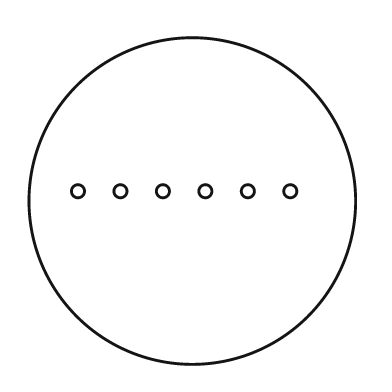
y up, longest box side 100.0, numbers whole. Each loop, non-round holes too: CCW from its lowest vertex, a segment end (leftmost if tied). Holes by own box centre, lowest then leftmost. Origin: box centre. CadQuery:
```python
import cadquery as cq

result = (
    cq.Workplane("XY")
    .moveTo(0.0, 0.0)
    .circle(50.0)
    .moveTo(-35.0, 3.0)
    .circle(2.0)
    .moveTo(-22.0, 3.0)
    .circle(2.0)
    .moveTo(-9.0, 3.0)
    .circle(2.0)
    .moveTo(4.0, 3.0)
    .circle(2.0)
    .moveTo(17.0, 3.0)
    .circle(2.0)
    .moveTo(30.0, 3.0)
    .circle(2.0)
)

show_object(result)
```